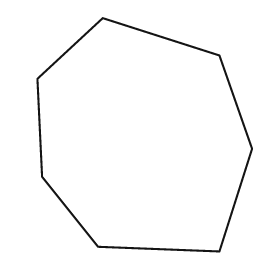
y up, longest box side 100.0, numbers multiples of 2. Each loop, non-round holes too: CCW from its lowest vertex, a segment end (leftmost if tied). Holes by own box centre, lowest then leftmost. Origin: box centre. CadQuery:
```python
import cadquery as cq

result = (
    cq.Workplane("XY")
    .moveTo(32.0, -50.0)
    .lineTo(46.0, -6.0)
    .lineTo(32.0, 34.0)
    .lineTo(-18.0, 50.0)
    .lineTo(-46.0, 24.0)
    .lineTo(-44.0, -18.0)
    .lineTo(-20.0, -48.0)
    .close()
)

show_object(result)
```